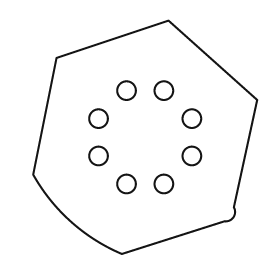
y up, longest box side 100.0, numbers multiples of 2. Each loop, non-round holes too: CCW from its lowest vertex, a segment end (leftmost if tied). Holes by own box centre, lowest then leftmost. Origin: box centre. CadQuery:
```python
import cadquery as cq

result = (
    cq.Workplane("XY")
    .moveTo(-10.0, -50.0)
    .lineTo(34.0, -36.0)
    .threePointArc((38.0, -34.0), (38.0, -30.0))
    .lineTo(48.0, 16.0)
    .lineTo(10.0, 50.0)
    .lineTo(-38.0, 34.0)
    .lineTo(-48.0, -16.0)
    .threePointArc((-32.0, -36.0), (-10.0, -50.0))
    .close()
    .moveTo(-8.0, -20.0)
    .circle(4.0)
    .moveTo(8.0, -20.0)
    .circle(4.0)
    .moveTo(-20.0, -8.0)
    .circle(4.0)
    .moveTo(20.0, -8.0)
    .circle(4.0)
    .moveTo(-20.0, 8.0)
    .circle(4.0)
    .moveTo(20.0, 8.0)
    .circle(4.0)
    .moveTo(-8.0, 20.0)
    .circle(4.0)
    .moveTo(8.0, 20.0)
    .circle(4.0)
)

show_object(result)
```